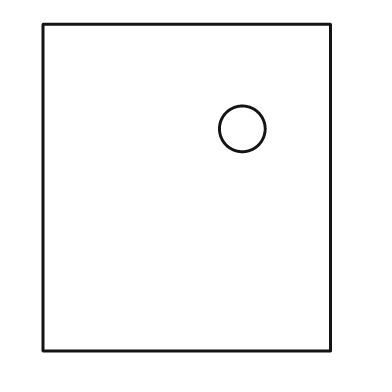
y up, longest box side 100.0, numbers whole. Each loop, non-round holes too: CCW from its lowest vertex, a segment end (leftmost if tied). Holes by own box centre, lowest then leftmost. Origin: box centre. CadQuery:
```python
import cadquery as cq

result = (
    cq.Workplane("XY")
    .moveTo(-44.0, -50.0)
    .lineTo(44.0, -50.0)
    .lineTo(44.0, 50.0)
    .lineTo(-44.0, 50.0)
    .close()
    .moveTo(17.0, 18.0)
    .circle(7.0)
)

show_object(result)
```